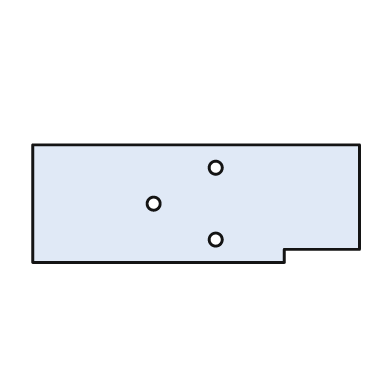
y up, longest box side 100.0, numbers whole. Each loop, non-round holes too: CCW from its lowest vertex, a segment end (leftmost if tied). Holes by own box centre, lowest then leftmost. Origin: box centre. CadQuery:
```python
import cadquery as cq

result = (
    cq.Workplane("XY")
    .moveTo(-50.0, -18.0)
    .lineTo(27.0, -18.0)
    .lineTo(27.0, -14.0)
    .lineTo(50.0, -14.0)
    .lineTo(50.0, 18.0)
    .lineTo(-50.0, 18.0)
    .close()
    .moveTo(6.0, -11.0)
    .circle(2.0)
    .moveTo(-13.0, 0.0)
    .circle(2.0)
    .moveTo(6.0, 11.0)
    .circle(2.0)
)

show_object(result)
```